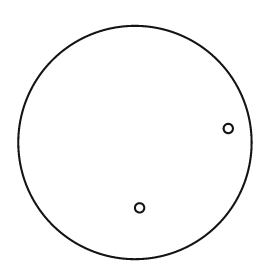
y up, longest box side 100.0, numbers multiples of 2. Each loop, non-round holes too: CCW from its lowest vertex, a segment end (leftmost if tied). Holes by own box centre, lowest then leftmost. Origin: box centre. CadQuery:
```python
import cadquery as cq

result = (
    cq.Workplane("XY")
    .moveTo(0.0, 0.0)
    .circle(50.0)
    .moveTo(2.0, -28.0)
    .circle(2.0)
    .moveTo(40.0, 6.0)
    .circle(2.0)
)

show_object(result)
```